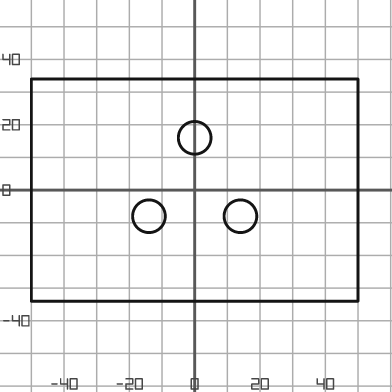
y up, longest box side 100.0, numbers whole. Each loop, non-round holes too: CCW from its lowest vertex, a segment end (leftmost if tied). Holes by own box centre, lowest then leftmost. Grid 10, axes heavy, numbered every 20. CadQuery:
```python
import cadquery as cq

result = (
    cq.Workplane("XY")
    .moveTo(-50.0, -34.0)
    .lineTo(50.0, -34.0)
    .lineTo(50.0, 34.0)
    .lineTo(-50.0, 34.0)
    .close()
    .moveTo(-14.0, -8.0)
    .circle(5.0)
    .moveTo(14.0, -8.0)
    .circle(5.0)
    .moveTo(0.0, 16.0)
    .circle(5.0)
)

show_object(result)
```